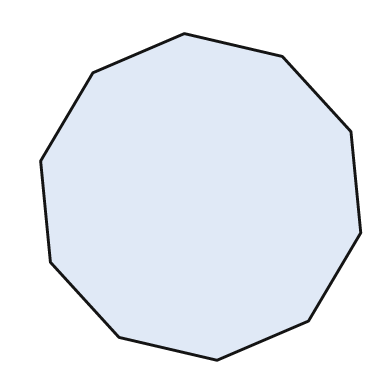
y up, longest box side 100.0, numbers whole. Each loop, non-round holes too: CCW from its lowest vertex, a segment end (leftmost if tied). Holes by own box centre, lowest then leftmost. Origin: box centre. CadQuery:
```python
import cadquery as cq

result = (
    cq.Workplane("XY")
    .moveTo(5.0, -50.0)
    .lineTo(33.0, -38.0)
    .lineTo(49.0, -11.0)
    .lineTo(46.0, 20.0)
    .lineTo(25.0, 43.0)
    .lineTo(-5.0, 50.0)
    .lineTo(-33.0, 38.0)
    .lineTo(-49.0, 11.0)
    .lineTo(-46.0, -20.0)
    .lineTo(-25.0, -43.0)
    .close()
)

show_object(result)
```